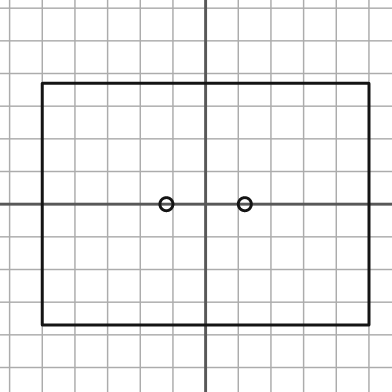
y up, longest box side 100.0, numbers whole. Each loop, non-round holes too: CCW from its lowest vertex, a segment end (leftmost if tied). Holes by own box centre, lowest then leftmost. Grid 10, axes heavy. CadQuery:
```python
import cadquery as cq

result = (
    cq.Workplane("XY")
    .moveTo(-50.0, -37.0)
    .lineTo(50.0, -37.0)
    .lineTo(50.0, 37.0)
    .lineTo(-50.0, 37.0)
    .close()
    .moveTo(-12.0, 0.0)
    .circle(2.0)
    .moveTo(12.0, 0.0)
    .circle(2.0)
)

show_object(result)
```